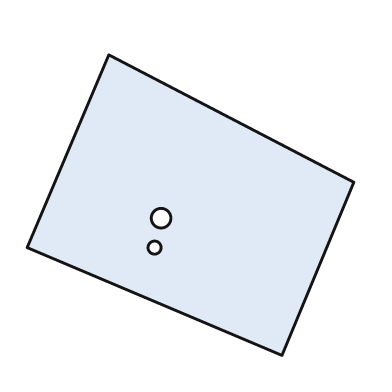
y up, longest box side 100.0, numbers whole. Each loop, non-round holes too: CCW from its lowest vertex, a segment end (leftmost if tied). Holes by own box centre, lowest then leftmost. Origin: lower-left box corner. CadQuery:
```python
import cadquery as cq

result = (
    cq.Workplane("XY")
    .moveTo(78.0, 0.0)
    .lineTo(100.0, 53.0)
    .lineTo(25.0, 92.0)
    .lineTo(0.0, 33.0)
    .close()
    .moveTo(39.0, 33.0)
    .circle(2.0)
    .moveTo(41.0, 42.0)
    .circle(3.0)
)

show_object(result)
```